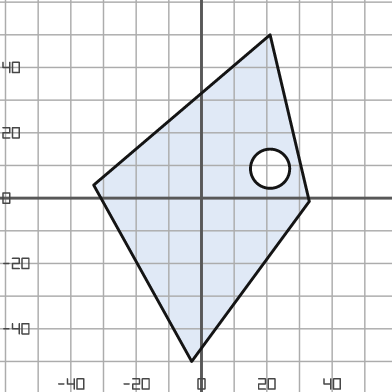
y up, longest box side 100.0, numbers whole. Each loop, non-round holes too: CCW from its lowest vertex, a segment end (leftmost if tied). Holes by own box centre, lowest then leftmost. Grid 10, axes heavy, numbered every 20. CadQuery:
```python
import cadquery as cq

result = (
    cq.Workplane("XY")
    .moveTo(-3.0, -50.0)
    .lineTo(33.0, -1.0)
    .lineTo(21.0, 50.0)
    .lineTo(-33.0, 4.0)
    .close()
    .moveTo(21.0, 9.0)
    .circle(6.0)
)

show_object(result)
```